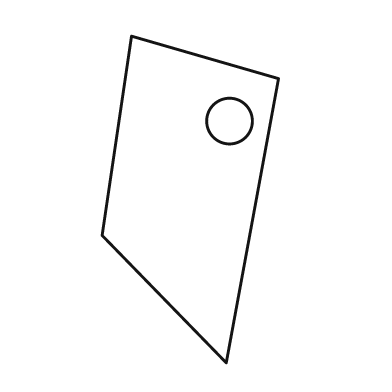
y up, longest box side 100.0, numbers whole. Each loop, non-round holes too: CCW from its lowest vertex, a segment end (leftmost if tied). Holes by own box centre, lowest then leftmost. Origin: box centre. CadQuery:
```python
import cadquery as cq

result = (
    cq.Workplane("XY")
    .moveTo(11.0, -50.0)
    .lineTo(27.0, 37.0)
    .lineTo(-18.0, 50.0)
    .lineTo(-27.0, -11.0)
    .close()
    .moveTo(12.0, 24.0)
    .circle(7.0)
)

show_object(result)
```